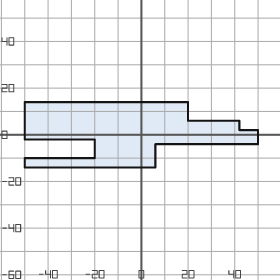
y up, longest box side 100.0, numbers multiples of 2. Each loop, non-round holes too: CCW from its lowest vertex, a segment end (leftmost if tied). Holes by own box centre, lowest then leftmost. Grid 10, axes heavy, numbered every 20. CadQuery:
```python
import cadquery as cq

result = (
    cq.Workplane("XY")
    .moveTo(-50.0, -14.0)
    .lineTo(6.0, -14.0)
    .lineTo(6.0, -4.0)
    .lineTo(50.0, -4.0)
    .lineTo(50.0, 2.0)
    .lineTo(42.0, 2.0)
    .lineTo(42.0, 6.0)
    .lineTo(20.0, 6.0)
    .lineTo(20.0, 14.0)
    .lineTo(-50.0, 14.0)
    .lineTo(-50.0, -2.0)
    .lineTo(-20.0, -2.0)
    .lineTo(-20.0, -10.0)
    .lineTo(-50.0, -10.0)
    .close()
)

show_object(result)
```